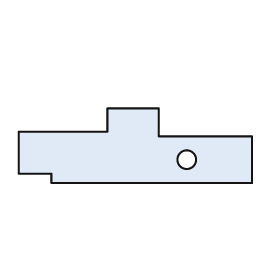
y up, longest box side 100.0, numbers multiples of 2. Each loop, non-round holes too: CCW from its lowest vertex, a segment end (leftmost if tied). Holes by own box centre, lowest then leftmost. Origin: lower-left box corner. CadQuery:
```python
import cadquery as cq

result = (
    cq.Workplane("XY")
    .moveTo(14.0, 0.0)
    .lineTo(100.0, 0.0)
    .lineTo(100.0, 20.0)
    .lineTo(60.0, 20.0)
    .lineTo(60.0, 32.0)
    .lineTo(38.0, 32.0)
    .lineTo(38.0, 22.0)
    .lineTo(0.0, 22.0)
    .lineTo(0.0, 4.0)
    .lineTo(14.0, 4.0)
    .close()
    .moveTo(72.0, 10.0)
    .circle(4.0)
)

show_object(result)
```